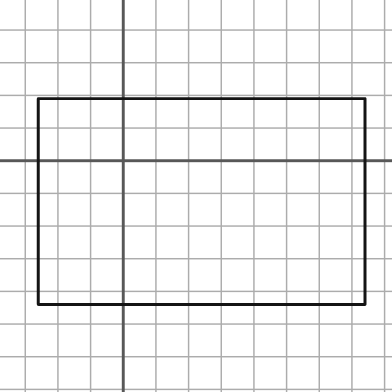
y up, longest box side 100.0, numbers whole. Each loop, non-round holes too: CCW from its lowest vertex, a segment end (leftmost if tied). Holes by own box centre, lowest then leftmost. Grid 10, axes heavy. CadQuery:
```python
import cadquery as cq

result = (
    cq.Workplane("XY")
    .moveTo(-26.0, -44.0)
    .lineTo(74.0, -44.0)
    .lineTo(74.0, 19.0)
    .lineTo(-26.0, 19.0)
    .close()
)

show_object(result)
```